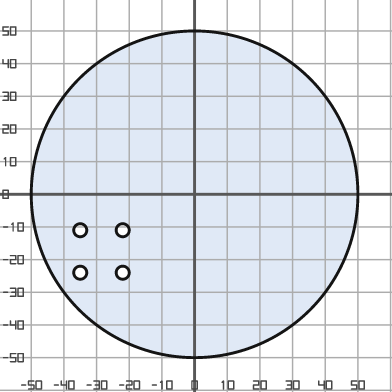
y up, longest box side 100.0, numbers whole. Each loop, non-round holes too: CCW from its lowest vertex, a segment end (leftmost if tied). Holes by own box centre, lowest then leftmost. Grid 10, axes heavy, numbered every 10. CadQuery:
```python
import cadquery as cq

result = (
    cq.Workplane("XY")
    .moveTo(0.0, 0.0)
    .circle(50.0)
    .moveTo(-35.0, -24.0)
    .circle(2.0)
    .moveTo(-22.0, -24.0)
    .circle(2.0)
    .moveTo(-35.0, -11.0)
    .circle(2.0)
    .moveTo(-22.0, -11.0)
    .circle(2.0)
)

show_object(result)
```